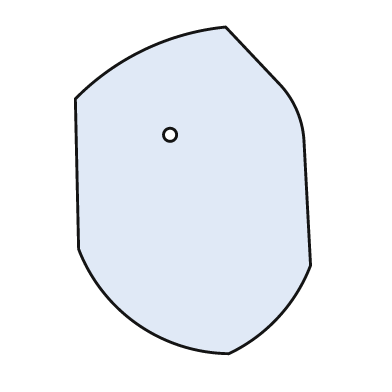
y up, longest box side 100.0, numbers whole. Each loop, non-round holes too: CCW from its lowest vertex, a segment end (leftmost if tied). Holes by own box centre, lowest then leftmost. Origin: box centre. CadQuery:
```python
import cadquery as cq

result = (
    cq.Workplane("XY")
    .moveTo(11.0, -50.0)
    .threePointArc((26.0, -39.0), (36.0, -23.0))
    .lineTo(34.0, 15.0)
    .threePointArc((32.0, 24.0), (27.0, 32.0))
    .lineTo(10.0, 50.0)
    .threePointArc((-15.0, 43.0), (-36.0, 28.0))
    .lineTo(-35.0, -18.0)
    .threePointArc((-17.0, -41.0), (11.0, -50.0))
    .close()
    .moveTo(-7.0, 17.0)
    .circle(2.0)
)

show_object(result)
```